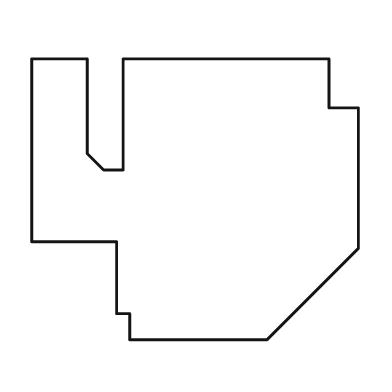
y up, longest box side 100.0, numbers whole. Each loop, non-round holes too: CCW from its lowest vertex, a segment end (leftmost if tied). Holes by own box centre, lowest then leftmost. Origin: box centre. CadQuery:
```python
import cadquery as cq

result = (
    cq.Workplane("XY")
    .moveTo(-20.0, -43.0)
    .lineTo(22.0, -43.0)
    .lineTo(50.0, -15.0)
    .lineTo(50.0, 28.0)
    .lineTo(41.0, 28.0)
    .lineTo(41.0, 43.0)
    .lineTo(-22.0, 43.0)
    .lineTo(-22.0, 9.0)
    .lineTo(-28.0, 9.0)
    .lineTo(-33.0, 14.0)
    .lineTo(-33.0, 43.0)
    .lineTo(-50.0, 43.0)
    .lineTo(-50.0, -13.0)
    .lineTo(-24.0, -13.0)
    .lineTo(-24.0, -35.0)
    .lineTo(-20.0, -35.0)
    .close()
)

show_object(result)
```